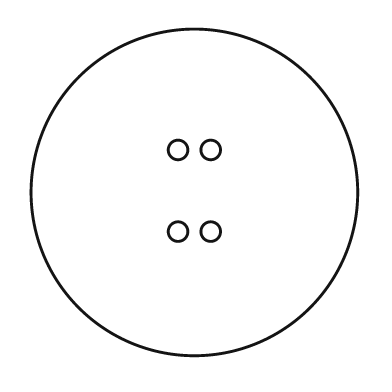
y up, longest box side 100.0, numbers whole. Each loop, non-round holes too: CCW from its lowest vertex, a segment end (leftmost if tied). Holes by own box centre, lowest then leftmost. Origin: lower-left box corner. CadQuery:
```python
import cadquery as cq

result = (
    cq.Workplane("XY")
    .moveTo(50.0, 50.0)
    .circle(50.0)
    .moveTo(45.0, 38.0)
    .circle(3.0)
    .moveTo(55.0, 38.0)
    .circle(3.0)
    .moveTo(45.0, 63.0)
    .circle(3.0)
    .moveTo(55.0, 63.0)
    .circle(3.0)
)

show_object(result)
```